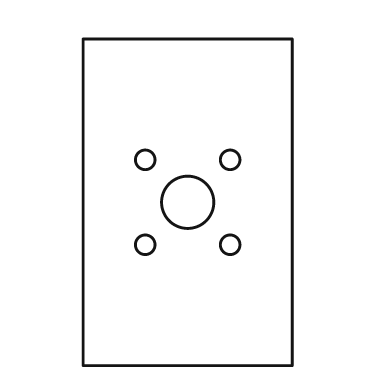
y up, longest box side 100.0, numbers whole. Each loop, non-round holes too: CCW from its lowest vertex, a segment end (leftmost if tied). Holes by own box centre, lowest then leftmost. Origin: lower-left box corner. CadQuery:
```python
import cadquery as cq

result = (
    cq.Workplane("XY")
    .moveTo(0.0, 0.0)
    .lineTo(64.0, 0.0)
    .lineTo(64.0, 100.0)
    .lineTo(0.0, 100.0)
    .close()
    .moveTo(19.0, 37.0)
    .circle(3.0)
    .moveTo(45.0, 37.0)
    .circle(3.0)
    .moveTo(32.0, 50.0)
    .circle(8.0)
    .moveTo(19.0, 63.0)
    .circle(3.0)
    .moveTo(45.0, 63.0)
    .circle(3.0)
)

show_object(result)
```